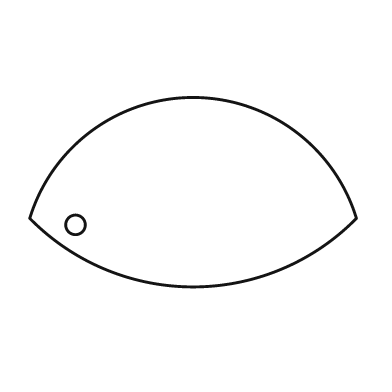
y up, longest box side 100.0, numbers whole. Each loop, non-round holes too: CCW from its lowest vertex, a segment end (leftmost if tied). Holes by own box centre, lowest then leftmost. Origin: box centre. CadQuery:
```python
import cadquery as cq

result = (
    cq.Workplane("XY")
    .moveTo(-50.0, -8.0)
    .threePointArc((0.0, -29.0), (50.0, -8.0))
    .threePointArc((0.0, 29.0), (-50.0, -8.0))
    .close()
    .moveTo(-36.0, -10.0)
    .circle(3.0)
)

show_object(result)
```